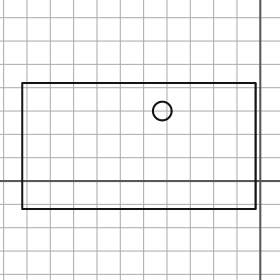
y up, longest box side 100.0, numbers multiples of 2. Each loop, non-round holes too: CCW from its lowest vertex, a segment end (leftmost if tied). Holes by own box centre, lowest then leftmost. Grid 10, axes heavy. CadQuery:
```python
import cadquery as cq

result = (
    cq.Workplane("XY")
    .moveTo(-102.0, -12.0)
    .lineTo(-2.0, -12.0)
    .lineTo(-2.0, 42.0)
    .lineTo(-102.0, 42.0)
    .close()
    .moveTo(-42.0, 30.0)
    .circle(4.0)
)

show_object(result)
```